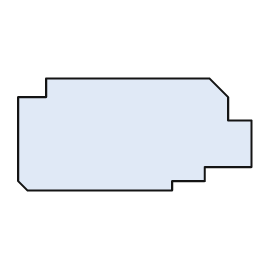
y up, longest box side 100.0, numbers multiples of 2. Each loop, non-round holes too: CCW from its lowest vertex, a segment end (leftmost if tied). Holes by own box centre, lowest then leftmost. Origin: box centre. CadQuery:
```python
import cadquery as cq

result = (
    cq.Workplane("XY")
    .moveTo(-46.0, -24.0)
    .lineTo(16.0, -24.0)
    .lineTo(16.0, -20.0)
    .lineTo(30.0, -20.0)
    .lineTo(30.0, -14.0)
    .lineTo(50.0, -14.0)
    .lineTo(50.0, 6.0)
    .lineTo(40.0, 6.0)
    .lineTo(40.0, 16.0)
    .lineTo(32.0, 24.0)
    .lineTo(-38.0, 24.0)
    .lineTo(-38.0, 16.0)
    .lineTo(-50.0, 16.0)
    .lineTo(-50.0, -20.0)
    .close()
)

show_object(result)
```